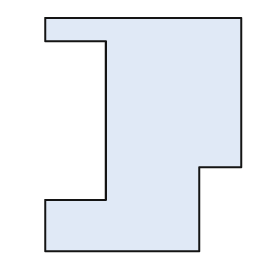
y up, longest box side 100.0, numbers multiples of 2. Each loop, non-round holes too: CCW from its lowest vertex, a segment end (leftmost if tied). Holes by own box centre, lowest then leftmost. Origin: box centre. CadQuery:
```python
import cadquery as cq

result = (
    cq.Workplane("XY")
    .moveTo(-42.0, -50.0)
    .lineTo(24.0, -50.0)
    .lineTo(24.0, -14.0)
    .lineTo(42.0, -14.0)
    .lineTo(42.0, 50.0)
    .lineTo(-42.0, 50.0)
    .lineTo(-42.0, 40.0)
    .lineTo(-16.0, 40.0)
    .lineTo(-16.0, -28.0)
    .lineTo(-42.0, -28.0)
    .close()
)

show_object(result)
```